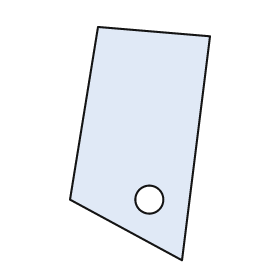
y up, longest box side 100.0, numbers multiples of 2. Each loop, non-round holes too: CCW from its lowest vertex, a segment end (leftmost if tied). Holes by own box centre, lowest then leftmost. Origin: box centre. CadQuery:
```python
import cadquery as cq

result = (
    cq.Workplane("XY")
    .moveTo(18.0, -50.0)
    .lineTo(30.0, 46.0)
    .lineTo(-18.0, 50.0)
    .lineTo(-30.0, -24.0)
    .close()
    .moveTo(4.0, -24.0)
    .circle(6.0)
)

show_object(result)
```